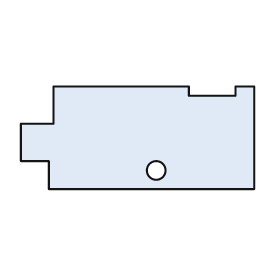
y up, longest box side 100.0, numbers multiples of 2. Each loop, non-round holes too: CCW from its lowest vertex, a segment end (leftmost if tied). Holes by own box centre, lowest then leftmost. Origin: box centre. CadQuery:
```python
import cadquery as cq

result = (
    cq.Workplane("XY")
    .moveTo(-38.0, -22.0)
    .lineTo(50.0, -22.0)
    .lineTo(50.0, 22.0)
    .lineTo(42.0, 22.0)
    .lineTo(42.0, 18.0)
    .lineTo(22.0, 18.0)
    .lineTo(22.0, 22.0)
    .lineTo(-36.0, 22.0)
    .lineTo(-36.0, 6.0)
    .lineTo(-50.0, 6.0)
    .lineTo(-50.0, -10.0)
    .lineTo(-38.0, -10.0)
    .close()
    .moveTo(8.0, -14.0)
    .circle(4.0)
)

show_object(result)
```